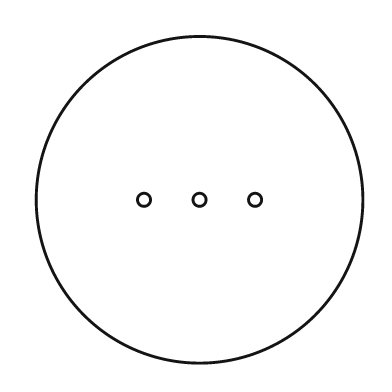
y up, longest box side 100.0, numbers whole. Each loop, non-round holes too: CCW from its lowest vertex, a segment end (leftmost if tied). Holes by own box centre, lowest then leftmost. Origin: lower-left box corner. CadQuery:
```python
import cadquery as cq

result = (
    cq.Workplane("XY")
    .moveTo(50.0, 50.0)
    .circle(50.0)
    .moveTo(33.0, 50.0)
    .circle(2.0)
    .moveTo(50.0, 50.0)
    .circle(2.0)
    .moveTo(67.0, 50.0)
    .circle(2.0)
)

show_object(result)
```